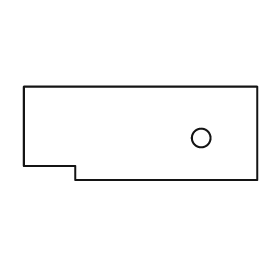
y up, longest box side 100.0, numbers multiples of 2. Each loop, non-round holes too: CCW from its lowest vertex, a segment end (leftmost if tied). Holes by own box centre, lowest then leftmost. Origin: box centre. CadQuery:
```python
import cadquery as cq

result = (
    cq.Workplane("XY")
    .moveTo(-28.0, -20.0)
    .lineTo(50.0, -20.0)
    .lineTo(50.0, 20.0)
    .lineTo(-50.0, 20.0)
    .lineTo(-50.0, -14.0)
    .lineTo(-28.0, -14.0)
    .close()
    .moveTo(26.0, -2.0)
    .circle(4.0)
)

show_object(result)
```